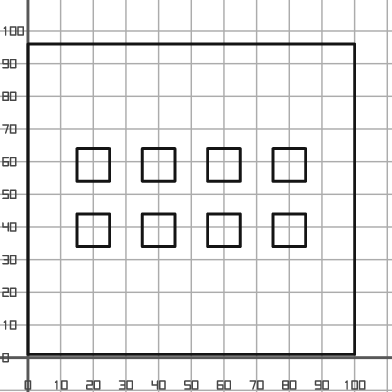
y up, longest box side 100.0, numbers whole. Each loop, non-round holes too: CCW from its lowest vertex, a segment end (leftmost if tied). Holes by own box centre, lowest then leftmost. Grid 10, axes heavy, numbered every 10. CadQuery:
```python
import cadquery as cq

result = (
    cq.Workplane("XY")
    .moveTo(0.0, 1.0)
    .lineTo(100.0, 1.0)
    .lineTo(100.0, 96.0)
    .lineTo(0.0, 96.0)
    .close()
    .moveTo(15.0, 34.0)
    .lineTo(25.0, 34.0)
    .lineTo(25.0, 44.0)
    .lineTo(15.0, 44.0)
    .close()
    .moveTo(35.0, 34.0)
    .lineTo(45.0, 34.0)
    .lineTo(45.0, 44.0)
    .lineTo(35.0, 44.0)
    .close()
    .moveTo(55.0, 34.0)
    .lineTo(65.0, 34.0)
    .lineTo(65.0, 44.0)
    .lineTo(55.0, 44.0)
    .close()
    .moveTo(75.0, 34.0)
    .lineTo(85.0, 34.0)
    .lineTo(85.0, 44.0)
    .lineTo(75.0, 44.0)
    .close()
    .moveTo(15.0, 54.0)
    .lineTo(25.0, 54.0)
    .lineTo(25.0, 64.0)
    .lineTo(15.0, 64.0)
    .close()
    .moveTo(35.0, 54.0)
    .lineTo(45.0, 54.0)
    .lineTo(45.0, 64.0)
    .lineTo(35.0, 64.0)
    .close()
    .moveTo(55.0, 54.0)
    .lineTo(65.0, 54.0)
    .lineTo(65.0, 64.0)
    .lineTo(55.0, 64.0)
    .close()
    .moveTo(75.0, 54.0)
    .lineTo(85.0, 54.0)
    .lineTo(85.0, 64.0)
    .lineTo(75.0, 64.0)
    .close()
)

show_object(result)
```